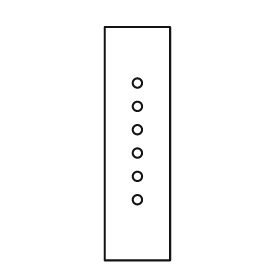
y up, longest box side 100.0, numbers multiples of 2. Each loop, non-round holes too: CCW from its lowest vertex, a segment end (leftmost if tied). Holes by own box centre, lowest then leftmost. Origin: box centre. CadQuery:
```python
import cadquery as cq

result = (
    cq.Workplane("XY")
    .moveTo(-14.0, -50.0)
    .lineTo(14.0, -50.0)
    .lineTo(14.0, 50.0)
    .lineTo(-14.0, 50.0)
    .close()
    .moveTo(0.0, -24.0)
    .circle(2.0)
    .moveTo(0.0, -14.0)
    .circle(2.0)
    .moveTo(0.0, -4.0)
    .circle(2.0)
    .moveTo(0.0, 6.0)
    .circle(2.0)
    .moveTo(0.0, 16.0)
    .circle(2.0)
    .moveTo(0.0, 26.0)
    .circle(2.0)
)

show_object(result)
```